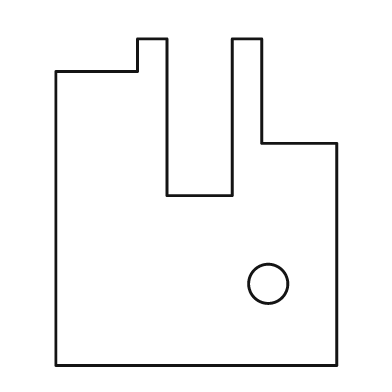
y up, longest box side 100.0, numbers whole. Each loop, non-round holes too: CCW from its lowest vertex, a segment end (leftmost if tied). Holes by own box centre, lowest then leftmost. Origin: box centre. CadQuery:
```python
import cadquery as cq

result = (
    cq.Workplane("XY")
    .moveTo(-43.0, -50.0)
    .lineTo(43.0, -50.0)
    .lineTo(43.0, 18.0)
    .lineTo(20.0, 18.0)
    .lineTo(20.0, 50.0)
    .lineTo(11.0, 50.0)
    .lineTo(11.0, 2.0)
    .lineTo(-9.0, 2.0)
    .lineTo(-9.0, 50.0)
    .lineTo(-18.0, 50.0)
    .lineTo(-18.0, 40.0)
    .lineTo(-43.0, 40.0)
    .close()
    .moveTo(22.0, -25.0)
    .circle(6.0)
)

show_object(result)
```